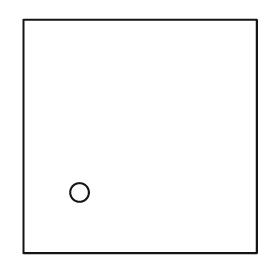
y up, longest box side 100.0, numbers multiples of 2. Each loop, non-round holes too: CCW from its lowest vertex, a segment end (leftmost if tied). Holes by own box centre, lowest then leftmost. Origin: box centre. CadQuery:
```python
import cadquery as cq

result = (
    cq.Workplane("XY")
    .moveTo(-50.0, -50.0)
    .lineTo(50.0, -50.0)
    .lineTo(50.0, 50.0)
    .lineTo(-50.0, 50.0)
    .close()
    .moveTo(-26.0, -24.0)
    .circle(4.0)
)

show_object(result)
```